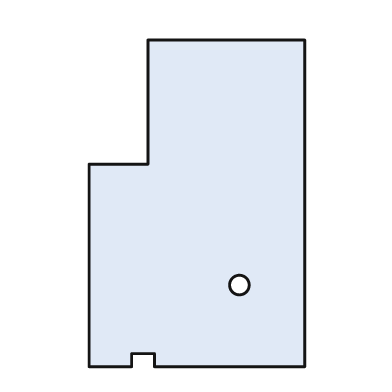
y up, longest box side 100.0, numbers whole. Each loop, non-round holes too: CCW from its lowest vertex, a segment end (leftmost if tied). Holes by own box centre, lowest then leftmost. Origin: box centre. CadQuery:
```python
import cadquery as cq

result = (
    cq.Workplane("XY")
    .moveTo(-33.0, -50.0)
    .lineTo(-20.0, -50.0)
    .lineTo(-20.0, -46.0)
    .lineTo(-13.0, -46.0)
    .lineTo(-13.0, -50.0)
    .lineTo(33.0, -50.0)
    .lineTo(33.0, 50.0)
    .lineTo(-15.0, 50.0)
    .lineTo(-15.0, 12.0)
    .lineTo(-33.0, 12.0)
    .close()
    .moveTo(13.0, -25.0)
    .circle(3.0)
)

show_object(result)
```